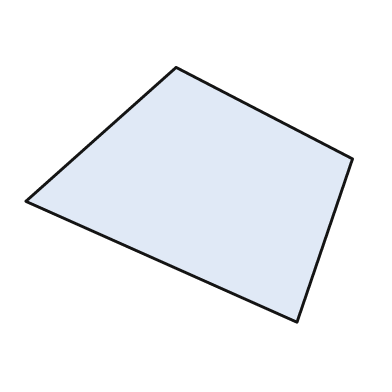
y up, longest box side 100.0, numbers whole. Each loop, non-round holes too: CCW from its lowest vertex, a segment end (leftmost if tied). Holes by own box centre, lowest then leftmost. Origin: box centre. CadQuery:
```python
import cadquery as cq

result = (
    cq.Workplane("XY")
    .moveTo(33.0, -39.0)
    .lineTo(50.0, 11.0)
    .lineTo(-4.0, 39.0)
    .lineTo(-50.0, -2.0)
    .close()
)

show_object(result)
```